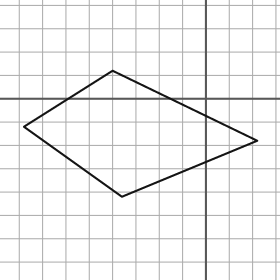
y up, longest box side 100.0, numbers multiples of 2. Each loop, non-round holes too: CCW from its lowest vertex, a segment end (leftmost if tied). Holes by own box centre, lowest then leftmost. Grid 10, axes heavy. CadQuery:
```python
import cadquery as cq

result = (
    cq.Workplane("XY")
    .moveTo(-36.0, -42.0)
    .lineTo(22.0, -18.0)
    .lineTo(-40.0, 12.0)
    .lineTo(-78.0, -12.0)
    .close()
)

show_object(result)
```